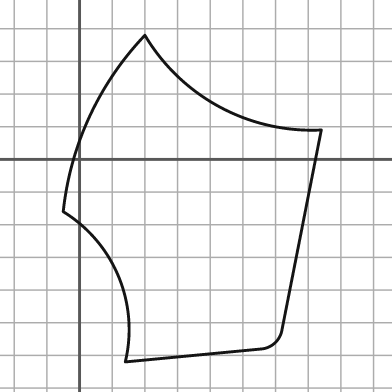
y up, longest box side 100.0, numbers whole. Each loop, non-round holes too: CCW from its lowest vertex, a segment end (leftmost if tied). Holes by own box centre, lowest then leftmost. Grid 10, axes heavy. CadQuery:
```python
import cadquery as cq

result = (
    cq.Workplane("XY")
    .moveTo(14.0, -62.0)
    .lineTo(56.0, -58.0)
    .threePointArc((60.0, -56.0), (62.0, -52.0))
    .lineTo(74.0, 9.0)
    .threePointArc((43.0, 16.0), (20.0, 38.0))
    .threePointArc((3.0, 13.0), (-5.0, -16.0))
    .threePointArc((12.0, -36.0), (14.0, -62.0))
    .close()
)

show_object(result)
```